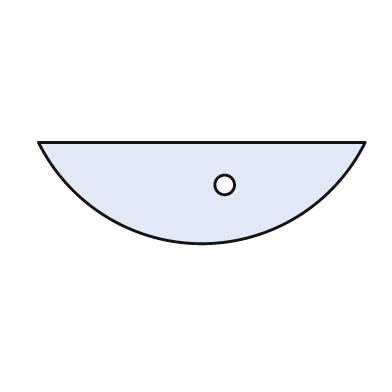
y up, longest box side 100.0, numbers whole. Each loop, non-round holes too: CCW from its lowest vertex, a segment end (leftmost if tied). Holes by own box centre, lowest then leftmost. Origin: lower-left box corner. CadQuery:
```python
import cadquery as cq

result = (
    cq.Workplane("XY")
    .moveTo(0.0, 31.0)
    .threePointArc((50.0, 0.0), (100.0, 31.0))
    .close()
    .moveTo(57.0, 18.0)
    .circle(3.0)
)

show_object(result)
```